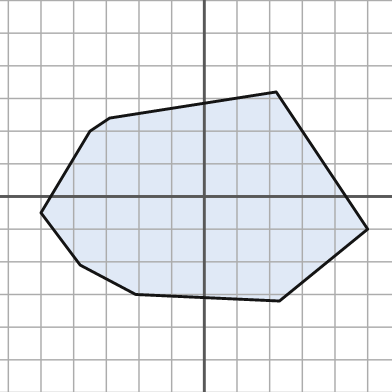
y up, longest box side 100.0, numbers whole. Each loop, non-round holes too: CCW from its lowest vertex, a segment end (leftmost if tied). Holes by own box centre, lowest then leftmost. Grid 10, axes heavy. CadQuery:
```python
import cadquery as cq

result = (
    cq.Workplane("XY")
    .moveTo(23.0, -32.0)
    .lineTo(50.0, -10.0)
    .lineTo(22.0, 32.0)
    .lineTo(-29.0, 24.0)
    .lineTo(-35.0, 20.0)
    .lineTo(-50.0, -5.0)
    .lineTo(-38.0, -21.0)
    .lineTo(-21.0, -30.0)
    .close()
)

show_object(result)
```